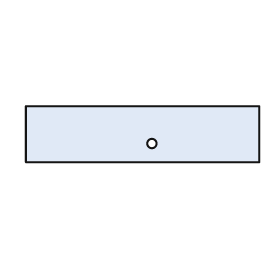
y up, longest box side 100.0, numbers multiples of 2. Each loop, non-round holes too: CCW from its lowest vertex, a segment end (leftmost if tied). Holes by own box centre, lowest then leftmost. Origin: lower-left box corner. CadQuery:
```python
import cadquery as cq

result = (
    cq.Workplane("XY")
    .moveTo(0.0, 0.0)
    .lineTo(100.0, 0.0)
    .lineTo(100.0, 24.0)
    .lineTo(0.0, 24.0)
    .close()
    .moveTo(54.0, 8.0)
    .circle(2.0)
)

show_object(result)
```